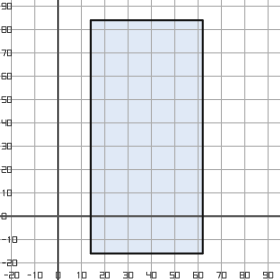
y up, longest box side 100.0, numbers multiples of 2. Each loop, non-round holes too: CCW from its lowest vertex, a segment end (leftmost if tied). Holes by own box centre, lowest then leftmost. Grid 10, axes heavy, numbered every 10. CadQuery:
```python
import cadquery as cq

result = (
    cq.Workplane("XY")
    .moveTo(14.0, -16.0)
    .lineTo(62.0, -16.0)
    .lineTo(62.0, 84.0)
    .lineTo(14.0, 84.0)
    .close()
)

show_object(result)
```